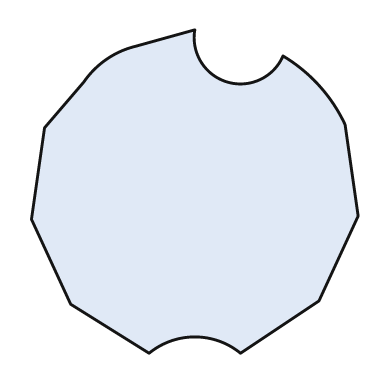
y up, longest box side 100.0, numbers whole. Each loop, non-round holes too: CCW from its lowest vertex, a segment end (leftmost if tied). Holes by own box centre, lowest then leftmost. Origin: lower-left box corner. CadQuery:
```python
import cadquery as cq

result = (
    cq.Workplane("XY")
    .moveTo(36.0, 0.0)
    .threePointArc((50.0, 5.0), (64.0, 0.0))
    .lineTo(88.0, 16.0)
    .lineTo(100.0, 42.0)
    .lineTo(96.0, 70.0)
    .threePointArc((88.0, 82.0), (77.0, 91.0))
    .threePointArc((60.0, 83.0), (50.0, 99.0))
    .lineTo(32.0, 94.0)
    .threePointArc((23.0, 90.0), (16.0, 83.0))
    .lineTo(4.0, 69.0)
    .lineTo(0.0, 41.0)
    .lineTo(12.0, 15.0)
    .close()
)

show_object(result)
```